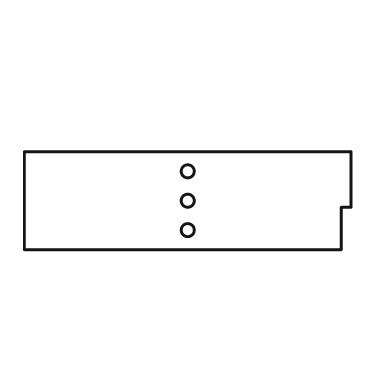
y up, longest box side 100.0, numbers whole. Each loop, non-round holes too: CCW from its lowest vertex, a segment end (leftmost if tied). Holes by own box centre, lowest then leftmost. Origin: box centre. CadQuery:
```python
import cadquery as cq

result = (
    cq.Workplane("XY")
    .moveTo(-50.0, -15.0)
    .lineTo(47.0, -15.0)
    .lineTo(47.0, -2.0)
    .lineTo(50.0, -2.0)
    .lineTo(50.0, 15.0)
    .lineTo(-50.0, 15.0)
    .close()
    .moveTo(0.0, -9.0)
    .circle(2.0)
    .moveTo(0.0, 0.0)
    .circle(2.0)
    .moveTo(0.0, 9.0)
    .circle(2.0)
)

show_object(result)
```